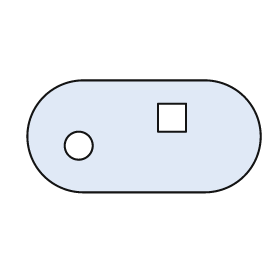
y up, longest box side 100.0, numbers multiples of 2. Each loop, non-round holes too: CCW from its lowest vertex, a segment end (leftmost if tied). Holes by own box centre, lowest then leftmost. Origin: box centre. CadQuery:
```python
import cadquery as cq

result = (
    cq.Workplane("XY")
    .moveTo(-26.0, -24.0)
    .lineTo(26.0, -24.0)
    .threePointArc((50.0, 0.0), (26.0, 24.0))
    .lineTo(-26.0, 24.0)
    .threePointArc((-50.0, 0.0), (-26.0, -24.0))
    .close()
    .moveTo(-28.0, -4.0)
    .circle(6.0)
    .moveTo(6.0, 2.0)
    .lineTo(18.0, 2.0)
    .lineTo(18.0, 14.0)
    .lineTo(6.0, 14.0)
    .close()
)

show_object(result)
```